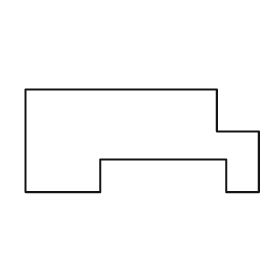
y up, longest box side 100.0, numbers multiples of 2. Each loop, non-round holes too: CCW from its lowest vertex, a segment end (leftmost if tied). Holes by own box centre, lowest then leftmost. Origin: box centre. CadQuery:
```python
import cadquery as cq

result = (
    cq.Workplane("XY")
    .moveTo(-50.0, -22.0)
    .lineTo(-18.0, -22.0)
    .lineTo(-18.0, -8.0)
    .lineTo(36.0, -8.0)
    .lineTo(36.0, -22.0)
    .lineTo(50.0, -22.0)
    .lineTo(50.0, 4.0)
    .lineTo(32.0, 4.0)
    .lineTo(32.0, 22.0)
    .lineTo(-50.0, 22.0)
    .close()
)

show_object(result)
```